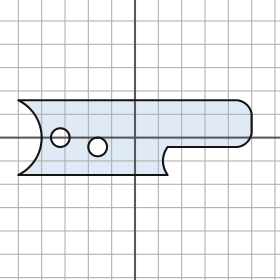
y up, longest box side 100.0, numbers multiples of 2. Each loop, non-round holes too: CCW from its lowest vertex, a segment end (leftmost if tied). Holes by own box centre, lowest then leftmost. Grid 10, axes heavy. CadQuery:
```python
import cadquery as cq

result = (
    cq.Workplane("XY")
    .moveTo(-50.0, -16.0)
    .lineTo(14.0, -16.0)
    .threePointArc((12.0, -10.0), (14.0, -4.0))
    .lineTo(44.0, -4.0)
    .threePointArc((48.0, -2.0), (50.0, 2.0))
    .lineTo(50.0, 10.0)
    .threePointArc((48.0, 14.0), (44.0, 16.0))
    .lineTo(-50.0, 16.0)
    .threePointArc((-40.0, 0.0), (-50.0, -16.0))
    .close()
    .moveTo(-16.0, -4.0)
    .circle(4.0)
    .moveTo(-32.0, 0.0)
    .circle(4.0)
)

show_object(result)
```